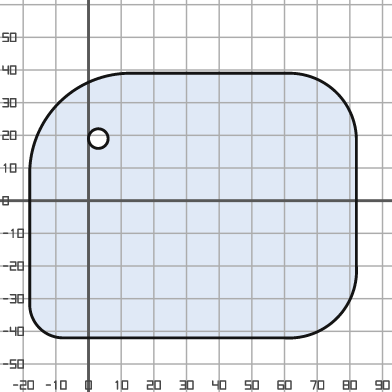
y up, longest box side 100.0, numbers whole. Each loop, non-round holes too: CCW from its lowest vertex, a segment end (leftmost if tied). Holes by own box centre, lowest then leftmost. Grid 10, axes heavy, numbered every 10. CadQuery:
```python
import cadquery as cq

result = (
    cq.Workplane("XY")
    .moveTo(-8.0, -42.0)
    .lineTo(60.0, -42.0)
    .threePointArc((76.0, -36.0), (82.0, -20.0))
    .lineTo(82.0, 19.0)
    .threePointArc((76.0, 33.0), (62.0, 39.0))
    .lineTo(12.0, 39.0)
    .threePointArc((-9.0, 30.0), (-18.0, 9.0))
    .lineTo(-18.0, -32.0)
    .threePointArc((-15.0, -39.0), (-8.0, -42.0))
    .close()
    .moveTo(3.0, 19.0)
    .circle(3.0)
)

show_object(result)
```